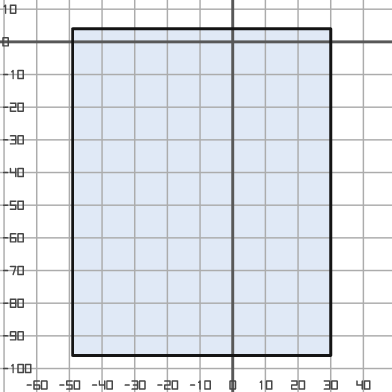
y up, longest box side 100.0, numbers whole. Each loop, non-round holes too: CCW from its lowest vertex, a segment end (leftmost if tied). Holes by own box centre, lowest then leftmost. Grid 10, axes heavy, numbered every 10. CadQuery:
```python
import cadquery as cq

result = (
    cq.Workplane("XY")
    .moveTo(-49.0, -96.0)
    .lineTo(30.0, -96.0)
    .lineTo(30.0, 4.0)
    .lineTo(-49.0, 4.0)
    .close()
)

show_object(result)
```